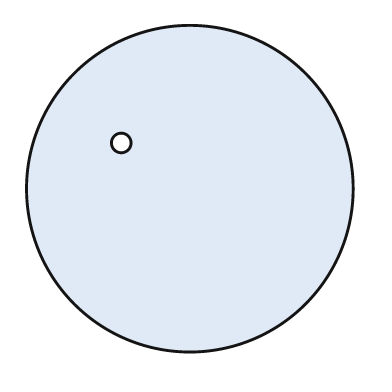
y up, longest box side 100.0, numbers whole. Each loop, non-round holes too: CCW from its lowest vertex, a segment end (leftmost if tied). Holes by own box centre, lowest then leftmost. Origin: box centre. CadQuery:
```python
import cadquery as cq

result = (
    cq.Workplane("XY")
    .moveTo(0.0, 0.0)
    .circle(50.0)
    .moveTo(-21.0, 14.0)
    .circle(3.0)
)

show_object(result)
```